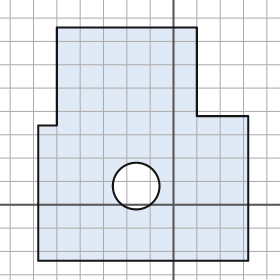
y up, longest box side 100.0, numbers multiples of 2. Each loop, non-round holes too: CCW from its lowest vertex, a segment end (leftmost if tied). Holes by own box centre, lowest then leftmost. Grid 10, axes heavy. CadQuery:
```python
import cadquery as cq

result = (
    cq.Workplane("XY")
    .moveTo(-58.0, -24.0)
    .lineTo(32.0, -24.0)
    .lineTo(32.0, 38.0)
    .lineTo(10.0, 38.0)
    .lineTo(10.0, 76.0)
    .lineTo(-50.0, 76.0)
    .lineTo(-50.0, 34.0)
    .lineTo(-58.0, 34.0)
    .close()
    .moveTo(-16.0, 8.0)
    .circle(10.0)
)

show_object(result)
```